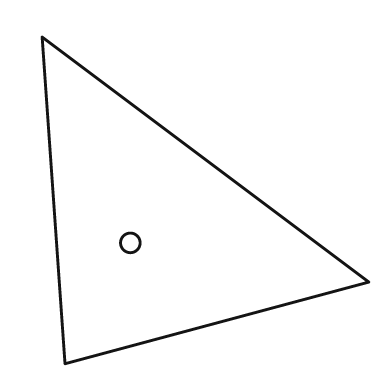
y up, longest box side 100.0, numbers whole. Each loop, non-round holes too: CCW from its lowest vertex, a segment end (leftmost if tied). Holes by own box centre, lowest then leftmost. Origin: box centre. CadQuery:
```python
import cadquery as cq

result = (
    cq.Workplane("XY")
    .moveTo(-43.0, -50.0)
    .lineTo(50.0, -25.0)
    .lineTo(-50.0, 50.0)
    .close()
    .moveTo(-23.0, -13.0)
    .circle(3.0)
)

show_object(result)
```